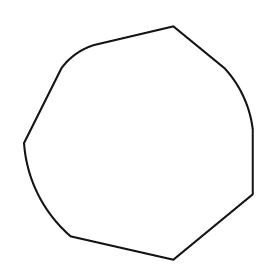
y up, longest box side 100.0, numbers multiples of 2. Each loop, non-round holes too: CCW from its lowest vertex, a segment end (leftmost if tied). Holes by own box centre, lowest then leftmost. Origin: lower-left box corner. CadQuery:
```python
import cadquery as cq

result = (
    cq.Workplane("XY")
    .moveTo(64.0, 0.0)
    .lineTo(98.0, 28.0)
    .lineTo(98.0, 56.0)
    .threePointArc((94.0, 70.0), (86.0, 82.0))
    .lineTo(64.0, 100.0)
    .lineTo(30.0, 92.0)
    .threePointArc((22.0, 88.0), (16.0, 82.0))
    .lineTo(0.0, 50.0)
    .threePointArc((6.0, 28.0), (20.0, 10.0))
    .close()
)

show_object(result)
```